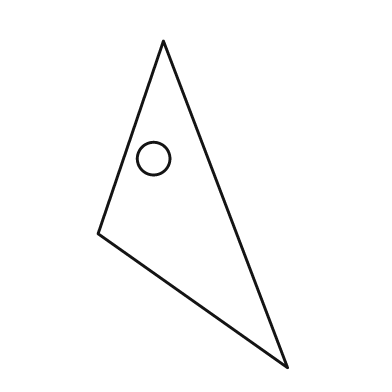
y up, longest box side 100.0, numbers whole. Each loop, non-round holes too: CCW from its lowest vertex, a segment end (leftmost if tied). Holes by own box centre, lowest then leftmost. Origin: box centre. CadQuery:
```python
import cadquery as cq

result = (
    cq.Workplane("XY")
    .moveTo(29.0, -50.0)
    .lineTo(-9.0, 50.0)
    .lineTo(-29.0, -9.0)
    .close()
    .moveTo(-12.0, 14.0)
    .circle(5.0)
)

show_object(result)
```